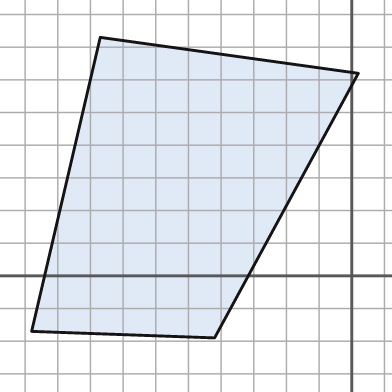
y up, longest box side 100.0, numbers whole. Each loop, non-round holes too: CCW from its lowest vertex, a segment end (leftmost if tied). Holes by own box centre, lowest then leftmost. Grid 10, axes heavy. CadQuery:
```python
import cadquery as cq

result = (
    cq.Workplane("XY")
    .moveTo(-42.0, -19.0)
    .lineTo(2.0, 62.0)
    .lineTo(-77.0, 73.0)
    .lineTo(-98.0, -17.0)
    .close()
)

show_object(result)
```